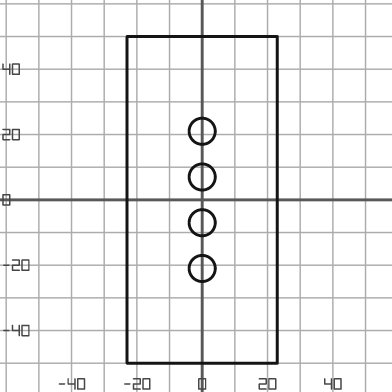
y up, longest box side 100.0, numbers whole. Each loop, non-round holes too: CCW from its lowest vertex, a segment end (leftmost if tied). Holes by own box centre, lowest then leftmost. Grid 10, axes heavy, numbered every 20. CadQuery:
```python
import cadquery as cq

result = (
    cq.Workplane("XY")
    .moveTo(-23.0, -50.0)
    .lineTo(23.0, -50.0)
    .lineTo(23.0, 50.0)
    .lineTo(-23.0, 50.0)
    .close()
    .moveTo(0.0, -21.0)
    .circle(4.0)
    .moveTo(0.0, -7.0)
    .circle(4.0)
    .moveTo(0.0, 7.0)
    .circle(4.0)
    .moveTo(0.0, 21.0)
    .circle(4.0)
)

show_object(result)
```